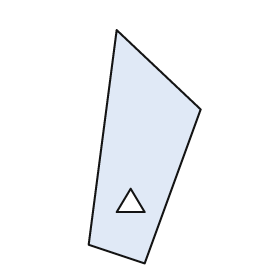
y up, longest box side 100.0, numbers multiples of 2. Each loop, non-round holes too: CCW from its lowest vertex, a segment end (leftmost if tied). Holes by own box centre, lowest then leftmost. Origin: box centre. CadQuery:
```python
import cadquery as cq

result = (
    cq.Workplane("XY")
    .moveTo(0.0, -50.0)
    .lineTo(24.0, 16.0)
    .lineTo(-12.0, 50.0)
    .lineTo(-24.0, -42.0)
    .close()
    .moveTo(-12.0, -28.0)
    .lineTo(0.0, -28.0)
    .lineTo(-6.0, -18.0)
    .close()
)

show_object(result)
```